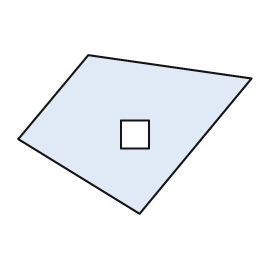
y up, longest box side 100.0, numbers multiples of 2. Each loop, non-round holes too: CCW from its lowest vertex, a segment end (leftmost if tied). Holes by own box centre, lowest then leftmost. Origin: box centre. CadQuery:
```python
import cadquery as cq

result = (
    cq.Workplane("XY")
    .moveTo(2.0, -34.0)
    .lineTo(50.0, 24.0)
    .lineTo(-20.0, 34.0)
    .lineTo(-50.0, -2.0)
    .close()
    .moveTo(-6.0, -6.0)
    .lineTo(6.0, -6.0)
    .lineTo(6.0, 6.0)
    .lineTo(-6.0, 6.0)
    .close()
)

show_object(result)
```